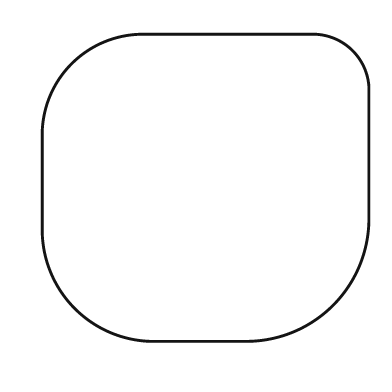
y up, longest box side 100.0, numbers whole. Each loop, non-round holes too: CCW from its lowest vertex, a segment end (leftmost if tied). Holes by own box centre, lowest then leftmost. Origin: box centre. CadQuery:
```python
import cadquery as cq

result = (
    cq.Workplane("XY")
    .moveTo(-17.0, -47.0)
    .lineTo(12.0, -47.0)
    .threePointArc((39.0, -36.0), (50.0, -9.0))
    .lineTo(50.0, 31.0)
    .threePointArc((45.0, 42.0), (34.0, 47.0))
    .lineTo(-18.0, 47.0)
    .threePointArc((-41.0, 38.0), (-50.0, 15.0))
    .lineTo(-50.0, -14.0)
    .threePointArc((-40.0, -37.0), (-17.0, -47.0))
    .close()
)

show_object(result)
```